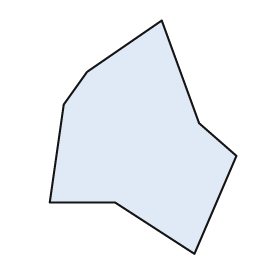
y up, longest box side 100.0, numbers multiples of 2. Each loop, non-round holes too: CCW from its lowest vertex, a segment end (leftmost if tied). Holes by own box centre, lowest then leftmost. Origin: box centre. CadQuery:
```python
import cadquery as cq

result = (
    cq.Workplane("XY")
    .moveTo(22.0, -50.0)
    .lineTo(40.0, -8.0)
    .lineTo(24.0, 6.0)
    .lineTo(8.0, 50.0)
    .lineTo(-24.0, 28.0)
    .lineTo(-34.0, 14.0)
    .lineTo(-40.0, -28.0)
    .lineTo(-12.0, -28.0)
    .close()
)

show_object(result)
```